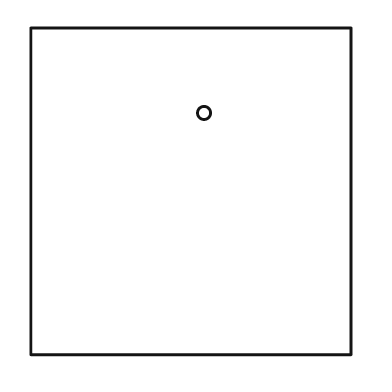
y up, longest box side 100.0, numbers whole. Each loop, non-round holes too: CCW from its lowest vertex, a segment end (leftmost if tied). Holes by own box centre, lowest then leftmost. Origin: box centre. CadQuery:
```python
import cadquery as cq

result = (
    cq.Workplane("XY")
    .moveTo(-49.0, -50.0)
    .lineTo(49.0, -50.0)
    .lineTo(49.0, 50.0)
    .lineTo(-49.0, 50.0)
    .close()
    .moveTo(4.0, 24.0)
    .circle(2.0)
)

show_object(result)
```